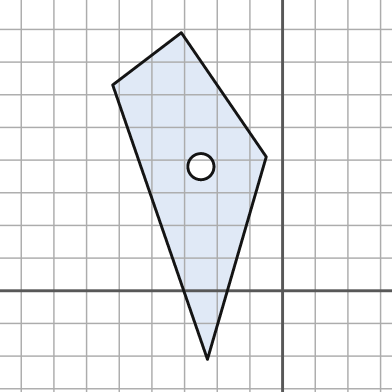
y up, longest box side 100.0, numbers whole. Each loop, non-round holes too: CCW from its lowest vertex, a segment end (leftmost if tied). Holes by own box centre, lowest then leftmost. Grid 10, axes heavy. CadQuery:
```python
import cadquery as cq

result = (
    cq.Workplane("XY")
    .moveTo(-23.0, -21.0)
    .lineTo(-5.0, 41.0)
    .lineTo(-31.0, 79.0)
    .lineTo(-52.0, 63.0)
    .close()
    .moveTo(-25.0, 38.0)
    .circle(4.0)
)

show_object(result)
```